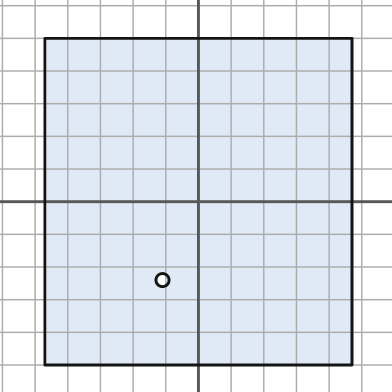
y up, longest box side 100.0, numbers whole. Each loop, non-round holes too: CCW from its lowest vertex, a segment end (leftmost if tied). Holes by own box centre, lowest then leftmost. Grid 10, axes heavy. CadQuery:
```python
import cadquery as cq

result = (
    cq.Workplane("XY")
    .moveTo(-47.0, -50.0)
    .lineTo(47.0, -50.0)
    .lineTo(47.0, 50.0)
    .lineTo(-47.0, 50.0)
    .close()
    .moveTo(-11.0, -24.0)
    .circle(2.0)
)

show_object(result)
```